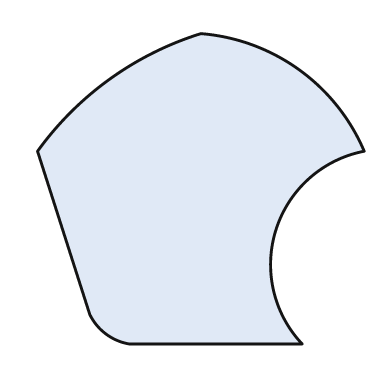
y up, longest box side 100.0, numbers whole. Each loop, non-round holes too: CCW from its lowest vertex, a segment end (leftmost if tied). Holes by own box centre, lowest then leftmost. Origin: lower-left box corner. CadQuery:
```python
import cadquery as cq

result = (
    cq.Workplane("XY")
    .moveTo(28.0, 0.0)
    .lineTo(81.0, 0.0)
    .threePointArc((73.0, 35.0), (100.0, 59.0))
    .threePointArc((80.0, 84.0), (50.0, 95.0))
    .threePointArc((22.0, 81.0), (0.0, 59.0))
    .lineTo(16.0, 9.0)
    .threePointArc((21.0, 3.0), (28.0, 0.0))
    .close()
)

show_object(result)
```